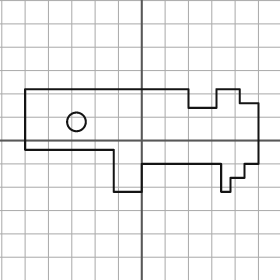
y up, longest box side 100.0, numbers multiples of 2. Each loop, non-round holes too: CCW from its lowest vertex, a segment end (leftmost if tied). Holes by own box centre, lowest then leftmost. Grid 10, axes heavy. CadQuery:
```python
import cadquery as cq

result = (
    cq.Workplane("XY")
    .moveTo(-12.0, -22.0)
    .lineTo(0.0, -22.0)
    .lineTo(0.0, -10.0)
    .lineTo(34.0, -10.0)
    .lineTo(34.0, -22.0)
    .lineTo(38.0, -22.0)
    .lineTo(38.0, -16.0)
    .lineTo(44.0, -16.0)
    .lineTo(44.0, -10.0)
    .lineTo(50.0, -10.0)
    .lineTo(50.0, 16.0)
    .lineTo(42.0, 16.0)
    .lineTo(42.0, 22.0)
    .lineTo(32.0, 22.0)
    .lineTo(32.0, 14.0)
    .lineTo(20.0, 14.0)
    .lineTo(20.0, 22.0)
    .lineTo(-50.0, 22.0)
    .lineTo(-50.0, -4.0)
    .lineTo(-12.0, -4.0)
    .close()
    .moveTo(-28.0, 8.0)
    .circle(4.0)
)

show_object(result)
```